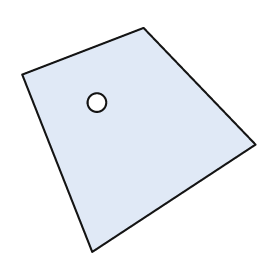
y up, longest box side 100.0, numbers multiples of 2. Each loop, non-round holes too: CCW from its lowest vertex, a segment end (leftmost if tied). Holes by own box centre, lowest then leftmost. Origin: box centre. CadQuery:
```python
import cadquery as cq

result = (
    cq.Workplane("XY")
    .moveTo(-20.0, -48.0)
    .lineTo(50.0, -2.0)
    .lineTo(2.0, 48.0)
    .lineTo(-50.0, 28.0)
    .close()
    .moveTo(-18.0, 16.0)
    .circle(4.0)
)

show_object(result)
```